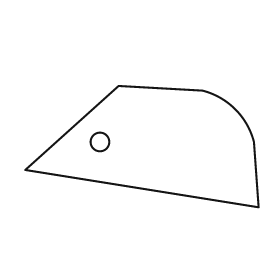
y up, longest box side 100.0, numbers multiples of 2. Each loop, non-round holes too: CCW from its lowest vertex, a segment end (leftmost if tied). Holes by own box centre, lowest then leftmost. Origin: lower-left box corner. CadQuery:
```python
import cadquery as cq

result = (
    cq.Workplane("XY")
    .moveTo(100.0, 0.0)
    .lineTo(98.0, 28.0)
    .threePointArc((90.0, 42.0), (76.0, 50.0))
    .lineTo(40.0, 52.0)
    .lineTo(0.0, 16.0)
    .close()
    .moveTo(32.0, 28.0)
    .circle(4.0)
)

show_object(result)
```